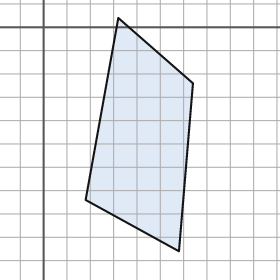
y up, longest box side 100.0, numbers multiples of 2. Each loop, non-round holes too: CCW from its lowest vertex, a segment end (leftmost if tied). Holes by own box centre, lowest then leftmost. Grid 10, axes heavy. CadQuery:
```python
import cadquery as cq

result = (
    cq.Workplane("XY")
    .moveTo(58.0, -96.0)
    .lineTo(64.0, -24.0)
    .lineTo(32.0, 4.0)
    .lineTo(18.0, -74.0)
    .close()
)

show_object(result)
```